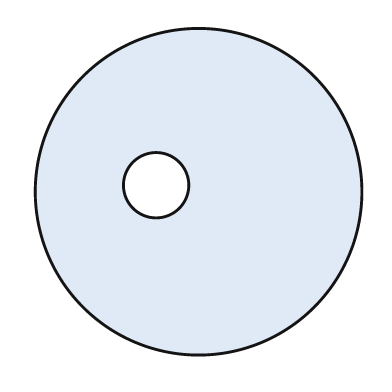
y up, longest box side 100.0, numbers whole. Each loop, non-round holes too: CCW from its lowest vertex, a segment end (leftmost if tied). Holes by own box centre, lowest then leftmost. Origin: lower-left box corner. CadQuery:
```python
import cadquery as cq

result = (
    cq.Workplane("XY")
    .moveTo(50.0, 50.0)
    .circle(50.0)
    .moveTo(37.0, 52.0)
    .circle(10.0)
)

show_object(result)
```